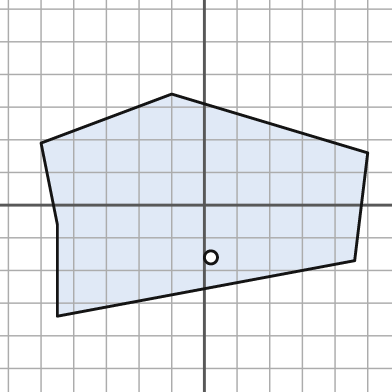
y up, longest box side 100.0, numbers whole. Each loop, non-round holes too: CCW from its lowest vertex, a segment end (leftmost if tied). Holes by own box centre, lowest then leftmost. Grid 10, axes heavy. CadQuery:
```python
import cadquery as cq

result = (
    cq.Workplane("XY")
    .moveTo(-45.0, -34.0)
    .lineTo(46.0, -17.0)
    .lineTo(50.0, 16.0)
    .lineTo(-10.0, 34.0)
    .lineTo(-50.0, 19.0)
    .lineTo(-45.0, -6.0)
    .close()
    .moveTo(2.0, -16.0)
    .circle(2.0)
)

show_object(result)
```